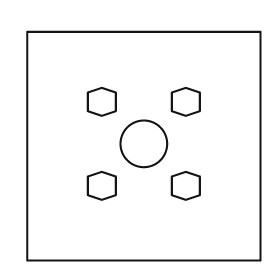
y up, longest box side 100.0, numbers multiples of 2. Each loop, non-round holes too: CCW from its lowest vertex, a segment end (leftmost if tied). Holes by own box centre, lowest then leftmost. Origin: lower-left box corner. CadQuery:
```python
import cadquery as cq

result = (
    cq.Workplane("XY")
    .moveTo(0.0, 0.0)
    .lineTo(100.0, 0.0)
    .lineTo(100.0, 98.0)
    .lineTo(0.0, 98.0)
    .close()
    .moveTo(32.0, 26.0)
    .lineTo(38.0, 28.0)
    .lineTo(38.0, 36.0)
    .lineTo(32.0, 38.0)
    .lineTo(26.0, 36.0)
    .lineTo(26.0, 28.0)
    .close()
    .moveTo(68.0, 26.0)
    .lineTo(74.0, 28.0)
    .lineTo(74.0, 36.0)
    .lineTo(68.0, 38.0)
    .lineTo(62.0, 36.0)
    .lineTo(62.0, 28.0)
    .close()
    .moveTo(50.0, 50.0)
    .circle(10.0)
    .moveTo(32.0, 62.0)
    .lineTo(38.0, 64.0)
    .lineTo(38.0, 72.0)
    .lineTo(32.0, 74.0)
    .lineTo(26.0, 72.0)
    .lineTo(26.0, 64.0)
    .close()
    .moveTo(68.0, 62.0)
    .lineTo(74.0, 64.0)
    .lineTo(74.0, 72.0)
    .lineTo(68.0, 74.0)
    .lineTo(62.0, 72.0)
    .lineTo(62.0, 64.0)
    .close()
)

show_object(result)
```